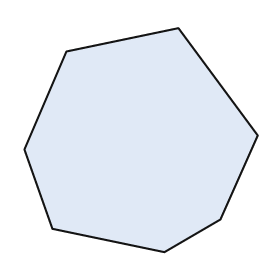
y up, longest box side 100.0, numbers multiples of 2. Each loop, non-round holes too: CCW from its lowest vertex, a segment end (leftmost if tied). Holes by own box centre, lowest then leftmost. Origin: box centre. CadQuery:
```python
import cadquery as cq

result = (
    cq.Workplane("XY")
    .moveTo(10.0, -48.0)
    .lineTo(34.0, -34.0)
    .lineTo(50.0, 2.0)
    .lineTo(16.0, 48.0)
    .lineTo(-32.0, 38.0)
    .lineTo(-50.0, -4.0)
    .lineTo(-38.0, -38.0)
    .close()
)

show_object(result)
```